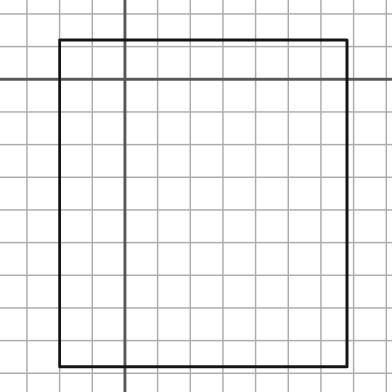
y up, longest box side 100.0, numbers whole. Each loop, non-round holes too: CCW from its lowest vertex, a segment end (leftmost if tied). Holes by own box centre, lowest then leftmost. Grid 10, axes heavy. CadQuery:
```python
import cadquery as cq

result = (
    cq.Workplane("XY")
    .moveTo(-20.0, -88.0)
    .lineTo(68.0, -88.0)
    .lineTo(68.0, 12.0)
    .lineTo(-20.0, 12.0)
    .close()
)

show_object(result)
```